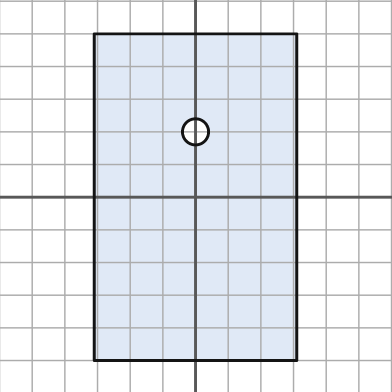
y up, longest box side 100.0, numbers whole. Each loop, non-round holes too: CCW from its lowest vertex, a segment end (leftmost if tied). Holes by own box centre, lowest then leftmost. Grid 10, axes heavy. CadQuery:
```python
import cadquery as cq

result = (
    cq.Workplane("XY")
    .moveTo(-31.0, -50.0)
    .lineTo(31.0, -50.0)
    .lineTo(31.0, 50.0)
    .lineTo(-31.0, 50.0)
    .close()
    .moveTo(0.0, 20.0)
    .circle(4.0)
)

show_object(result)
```